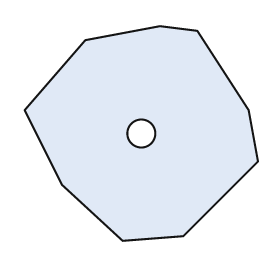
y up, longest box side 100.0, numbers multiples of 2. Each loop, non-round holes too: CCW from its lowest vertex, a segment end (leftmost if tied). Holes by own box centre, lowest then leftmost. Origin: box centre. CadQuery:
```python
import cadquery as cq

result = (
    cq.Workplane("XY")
    .moveTo(-8.0, -46.0)
    .lineTo(18.0, -44.0)
    .lineTo(50.0, -12.0)
    .lineTo(46.0, 10.0)
    .lineTo(24.0, 44.0)
    .lineTo(8.0, 46.0)
    .lineTo(-24.0, 40.0)
    .lineTo(-50.0, 10.0)
    .lineTo(-34.0, -22.0)
    .close()
    .moveTo(0.0, 0.0)
    .circle(6.0)
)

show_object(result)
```